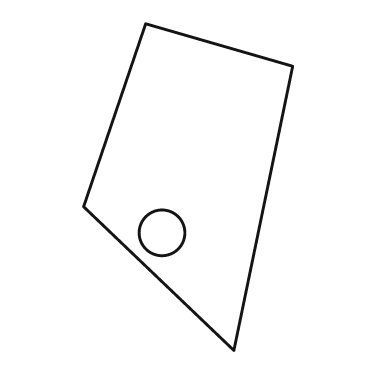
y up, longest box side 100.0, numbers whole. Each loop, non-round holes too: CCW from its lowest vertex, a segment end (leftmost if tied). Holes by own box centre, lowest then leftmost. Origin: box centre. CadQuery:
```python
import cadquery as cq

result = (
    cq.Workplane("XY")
    .moveTo(14.0, -50.0)
    .lineTo(32.0, 37.0)
    .lineTo(-13.0, 50.0)
    .lineTo(-32.0, -6.0)
    .close()
    .moveTo(-8.0, -14.0)
    .circle(7.0)
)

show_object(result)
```